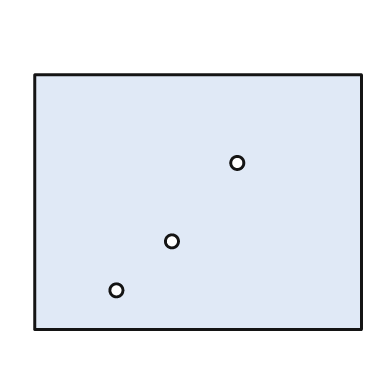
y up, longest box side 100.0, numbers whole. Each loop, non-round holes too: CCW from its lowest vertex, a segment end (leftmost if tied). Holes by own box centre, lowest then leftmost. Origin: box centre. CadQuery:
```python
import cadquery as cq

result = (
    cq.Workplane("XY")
    .moveTo(-50.0, -39.0)
    .lineTo(50.0, -39.0)
    .lineTo(50.0, 39.0)
    .lineTo(-50.0, 39.0)
    .close()
    .moveTo(-25.0, -27.0)
    .circle(2.0)
    .moveTo(-8.0, -12.0)
    .circle(2.0)
    .moveTo(12.0, 12.0)
    .circle(2.0)
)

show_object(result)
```